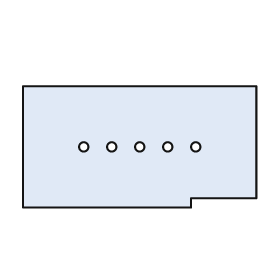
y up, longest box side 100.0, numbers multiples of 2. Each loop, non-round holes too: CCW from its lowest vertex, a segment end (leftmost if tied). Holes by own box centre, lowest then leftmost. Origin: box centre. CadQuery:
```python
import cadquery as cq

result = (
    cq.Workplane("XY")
    .moveTo(-50.0, -26.0)
    .lineTo(22.0, -26.0)
    .lineTo(22.0, -22.0)
    .lineTo(50.0, -22.0)
    .lineTo(50.0, 26.0)
    .lineTo(-50.0, 26.0)
    .close()
    .moveTo(-24.0, 0.0)
    .circle(2.0)
    .moveTo(-12.0, 0.0)
    .circle(2.0)
    .moveTo(0.0, 0.0)
    .circle(2.0)
    .moveTo(12.0, 0.0)
    .circle(2.0)
    .moveTo(24.0, 0.0)
    .circle(2.0)
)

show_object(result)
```